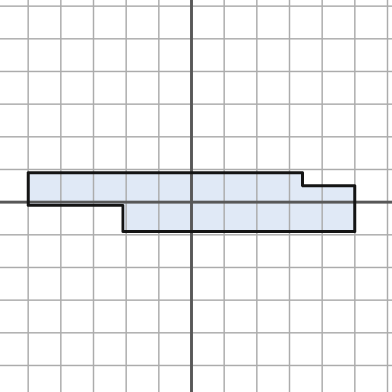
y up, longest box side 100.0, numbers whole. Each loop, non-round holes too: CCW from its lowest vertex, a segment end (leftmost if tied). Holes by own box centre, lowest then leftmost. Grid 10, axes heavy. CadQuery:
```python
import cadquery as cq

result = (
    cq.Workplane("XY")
    .moveTo(-21.0, -9.0)
    .lineTo(50.0, -9.0)
    .lineTo(50.0, 5.0)
    .lineTo(34.0, 5.0)
    .lineTo(34.0, 9.0)
    .lineTo(-50.0, 9.0)
    .lineTo(-50.0, -1.0)
    .lineTo(-21.0, -1.0)
    .close()
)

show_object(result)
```